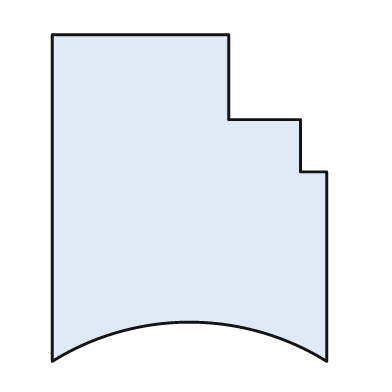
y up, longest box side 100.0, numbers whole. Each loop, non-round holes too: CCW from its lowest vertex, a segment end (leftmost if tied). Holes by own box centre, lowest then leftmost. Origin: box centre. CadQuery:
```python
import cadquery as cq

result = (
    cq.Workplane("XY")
    .moveTo(-42.0, -50.0)
    .threePointArc((0.0, -38.0), (42.0, -50.0))
    .lineTo(42.0, 8.0)
    .lineTo(34.0, 8.0)
    .lineTo(34.0, 24.0)
    .lineTo(12.0, 24.0)
    .lineTo(12.0, 50.0)
    .lineTo(-42.0, 50.0)
    .close()
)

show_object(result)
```